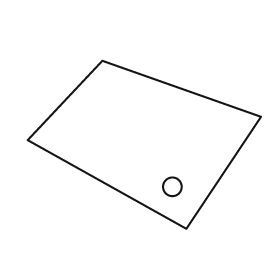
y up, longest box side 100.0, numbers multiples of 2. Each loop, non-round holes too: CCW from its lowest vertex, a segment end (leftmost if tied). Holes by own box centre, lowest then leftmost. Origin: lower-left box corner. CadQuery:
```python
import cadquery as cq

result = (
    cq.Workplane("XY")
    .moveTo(68.0, 0.0)
    .lineTo(100.0, 48.0)
    .lineTo(32.0, 72.0)
    .lineTo(0.0, 38.0)
    .close()
    .moveTo(62.0, 18.0)
    .circle(4.0)
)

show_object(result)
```